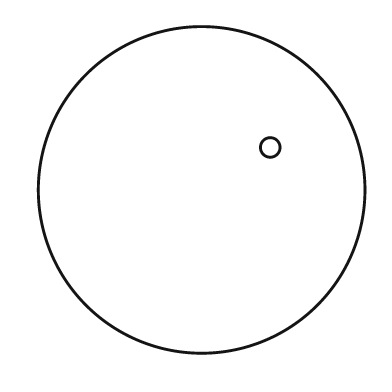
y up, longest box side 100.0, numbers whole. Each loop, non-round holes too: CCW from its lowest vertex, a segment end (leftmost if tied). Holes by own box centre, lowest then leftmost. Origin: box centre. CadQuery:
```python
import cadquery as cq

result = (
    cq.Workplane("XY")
    .moveTo(0.0, 0.0)
    .circle(50.0)
    .moveTo(21.0, 13.0)
    .circle(3.0)
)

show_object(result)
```